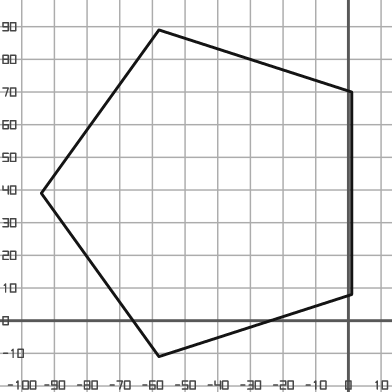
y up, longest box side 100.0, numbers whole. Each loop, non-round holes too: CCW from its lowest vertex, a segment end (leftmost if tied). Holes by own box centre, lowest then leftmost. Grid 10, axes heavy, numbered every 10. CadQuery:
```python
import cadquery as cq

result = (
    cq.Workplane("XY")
    .moveTo(-58.0, -11.0)
    .lineTo(1.0, 8.0)
    .lineTo(1.0, 70.0)
    .lineTo(-58.0, 89.0)
    .lineTo(-94.0, 39.0)
    .close()
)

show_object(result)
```